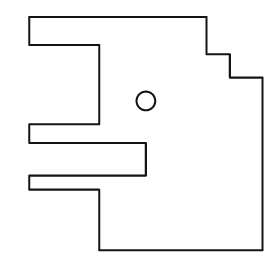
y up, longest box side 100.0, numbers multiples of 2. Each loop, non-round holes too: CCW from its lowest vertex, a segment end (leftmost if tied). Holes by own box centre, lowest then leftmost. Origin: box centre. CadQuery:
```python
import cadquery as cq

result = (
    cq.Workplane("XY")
    .moveTo(-20.0, -50.0)
    .lineTo(50.0, -50.0)
    .lineTo(50.0, 24.0)
    .lineTo(36.0, 24.0)
    .lineTo(36.0, 34.0)
    .lineTo(26.0, 34.0)
    .lineTo(26.0, 50.0)
    .lineTo(-50.0, 50.0)
    .lineTo(-50.0, 38.0)
    .lineTo(-20.0, 38.0)
    .lineTo(-20.0, 4.0)
    .lineTo(-50.0, 4.0)
    .lineTo(-50.0, -4.0)
    .lineTo(0.0, -4.0)
    .lineTo(0.0, -18.0)
    .lineTo(-50.0, -18.0)
    .lineTo(-50.0, -24.0)
    .lineTo(-20.0, -24.0)
    .close()
    .moveTo(0.0, 14.0)
    .circle(4.0)
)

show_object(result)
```